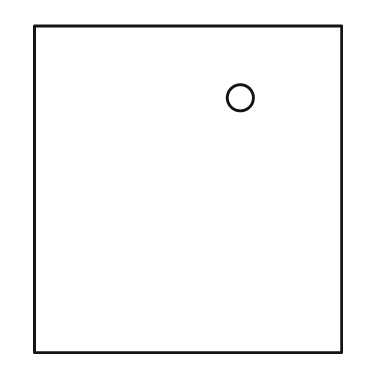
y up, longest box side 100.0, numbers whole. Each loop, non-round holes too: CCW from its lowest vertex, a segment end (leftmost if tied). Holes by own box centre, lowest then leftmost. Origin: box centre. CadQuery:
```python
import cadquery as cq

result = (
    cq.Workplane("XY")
    .moveTo(-47.0, -50.0)
    .lineTo(47.0, -50.0)
    .lineTo(47.0, 50.0)
    .lineTo(-47.0, 50.0)
    .close()
    .moveTo(16.0, 28.0)
    .circle(4.0)
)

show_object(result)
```